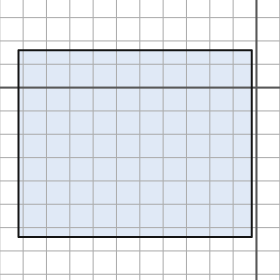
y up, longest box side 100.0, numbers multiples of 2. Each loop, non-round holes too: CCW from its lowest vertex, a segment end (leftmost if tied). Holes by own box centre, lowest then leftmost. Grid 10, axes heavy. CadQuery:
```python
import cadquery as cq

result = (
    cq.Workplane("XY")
    .moveTo(-102.0, -64.0)
    .lineTo(-2.0, -64.0)
    .lineTo(-2.0, 16.0)
    .lineTo(-102.0, 16.0)
    .close()
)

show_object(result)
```